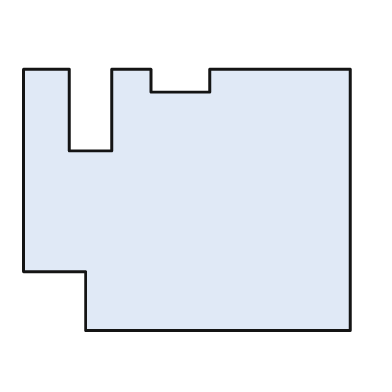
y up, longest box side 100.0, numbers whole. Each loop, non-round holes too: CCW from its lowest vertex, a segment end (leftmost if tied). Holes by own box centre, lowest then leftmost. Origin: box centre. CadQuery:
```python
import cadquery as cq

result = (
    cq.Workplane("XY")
    .moveTo(-31.0, -40.0)
    .lineTo(50.0, -40.0)
    .lineTo(50.0, 40.0)
    .lineTo(7.0, 40.0)
    .lineTo(7.0, 33.0)
    .lineTo(-11.0, 33.0)
    .lineTo(-11.0, 40.0)
    .lineTo(-23.0, 40.0)
    .lineTo(-23.0, 15.0)
    .lineTo(-36.0, 15.0)
    .lineTo(-36.0, 40.0)
    .lineTo(-50.0, 40.0)
    .lineTo(-50.0, -22.0)
    .lineTo(-31.0, -22.0)
    .close()
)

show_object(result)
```